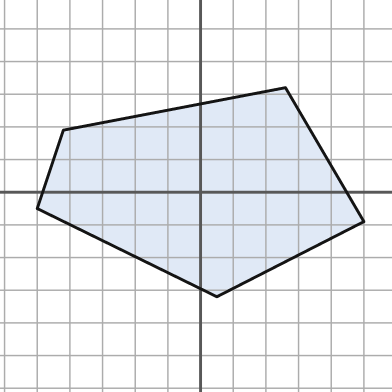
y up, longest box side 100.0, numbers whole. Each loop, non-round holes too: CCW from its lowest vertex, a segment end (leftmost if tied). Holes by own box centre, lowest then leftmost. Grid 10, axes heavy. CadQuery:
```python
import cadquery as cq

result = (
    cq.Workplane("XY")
    .moveTo(5.0, -32.0)
    .lineTo(50.0, -9.0)
    .lineTo(26.0, 32.0)
    .lineTo(-42.0, 19.0)
    .lineTo(-50.0, -5.0)
    .close()
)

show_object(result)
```